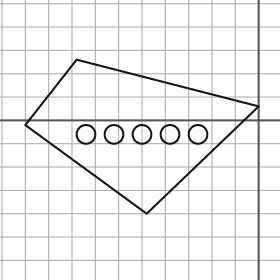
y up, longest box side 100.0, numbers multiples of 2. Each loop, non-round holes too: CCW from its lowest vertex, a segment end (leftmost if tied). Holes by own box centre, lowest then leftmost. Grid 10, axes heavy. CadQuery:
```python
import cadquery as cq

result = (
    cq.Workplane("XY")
    .moveTo(-48.0, -40.0)
    .lineTo(0.0, 6.0)
    .lineTo(-78.0, 26.0)
    .lineTo(-100.0, -2.0)
    .close()
    .moveTo(-74.0, -6.0)
    .circle(4.0)
    .moveTo(-62.0, -6.0)
    .circle(4.0)
    .moveTo(-50.0, -6.0)
    .circle(4.0)
    .moveTo(-38.0, -6.0)
    .circle(4.0)
    .moveTo(-26.0, -6.0)
    .circle(4.0)
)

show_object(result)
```